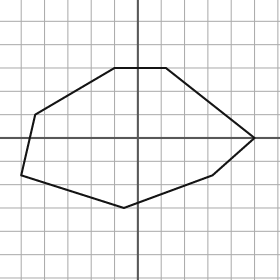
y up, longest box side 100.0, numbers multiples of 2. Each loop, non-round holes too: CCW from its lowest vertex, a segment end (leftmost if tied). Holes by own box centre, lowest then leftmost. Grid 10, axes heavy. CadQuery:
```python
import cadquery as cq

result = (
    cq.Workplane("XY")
    .moveTo(-6.0, -30.0)
    .lineTo(32.0, -16.0)
    .lineTo(50.0, 0.0)
    .lineTo(12.0, 30.0)
    .lineTo(-10.0, 30.0)
    .lineTo(-44.0, 10.0)
    .lineTo(-50.0, -16.0)
    .close()
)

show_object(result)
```